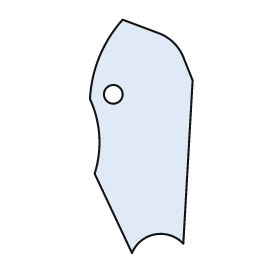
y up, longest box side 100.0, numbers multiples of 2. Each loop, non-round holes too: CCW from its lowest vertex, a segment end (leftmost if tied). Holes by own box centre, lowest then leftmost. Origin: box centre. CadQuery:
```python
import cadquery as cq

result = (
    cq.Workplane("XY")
    .moveTo(-4.0, -50.0)
    .threePointArc((6.0, -42.0), (18.0, -46.0))
    .lineTo(22.0, 24.0)
    .lineTo(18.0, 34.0)
    .threePointArc((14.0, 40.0), (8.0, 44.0))
    .lineTo(-8.0, 50.0)
    .threePointArc((-18.0, 34.0), (-22.0, 16.0))
    .threePointArc((-18.0, 0.0), (-20.0, -16.0))
    .close()
    .moveTo(-12.0, 18.0)
    .circle(4.0)
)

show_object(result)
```